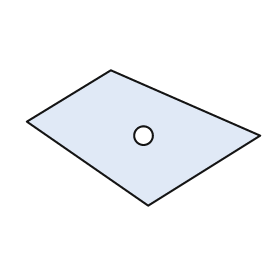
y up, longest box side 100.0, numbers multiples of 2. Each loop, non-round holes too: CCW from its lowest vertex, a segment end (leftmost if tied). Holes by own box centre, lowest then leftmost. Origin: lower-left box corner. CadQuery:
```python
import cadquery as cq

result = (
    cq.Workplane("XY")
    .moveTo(52.0, 0.0)
    .lineTo(100.0, 30.0)
    .lineTo(36.0, 58.0)
    .lineTo(0.0, 36.0)
    .close()
    .moveTo(50.0, 30.0)
    .circle(4.0)
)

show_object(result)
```